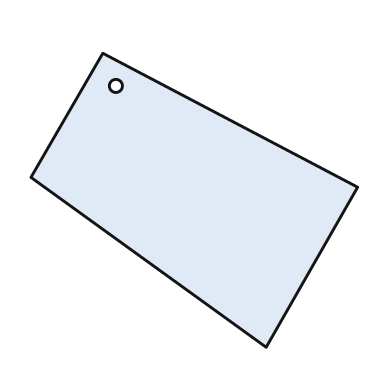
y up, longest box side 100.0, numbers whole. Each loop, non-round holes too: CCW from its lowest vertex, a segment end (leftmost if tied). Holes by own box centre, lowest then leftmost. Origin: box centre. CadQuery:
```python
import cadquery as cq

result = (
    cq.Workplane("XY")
    .moveTo(22.0, -45.0)
    .lineTo(50.0, 4.0)
    .lineTo(-28.0, 45.0)
    .lineTo(-50.0, 7.0)
    .close()
    .moveTo(-24.0, 35.0)
    .circle(2.0)
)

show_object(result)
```